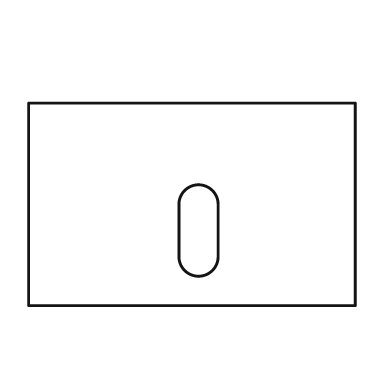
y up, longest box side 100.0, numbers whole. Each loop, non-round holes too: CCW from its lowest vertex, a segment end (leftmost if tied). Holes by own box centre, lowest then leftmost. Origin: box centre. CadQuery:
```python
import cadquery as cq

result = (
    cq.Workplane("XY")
    .moveTo(-50.0, -31.0)
    .lineTo(50.0, -31.0)
    .lineTo(50.0, 31.0)
    .lineTo(-50.0, 31.0)
    .close()
    .moveTo(-4.0, -16.0)
    .threePointArc((2.0, -22.0), (8.0, -16.0))
    .lineTo(8.0, 0.0)
    .threePointArc((2.0, 6.0), (-4.0, 0.0))
    .close()
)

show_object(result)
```